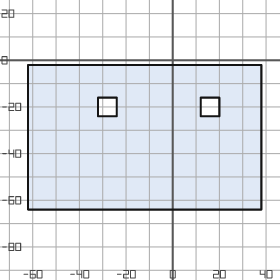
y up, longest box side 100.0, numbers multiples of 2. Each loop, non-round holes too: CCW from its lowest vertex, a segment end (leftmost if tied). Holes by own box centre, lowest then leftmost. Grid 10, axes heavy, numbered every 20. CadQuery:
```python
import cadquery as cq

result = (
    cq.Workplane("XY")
    .moveTo(-62.0, -64.0)
    .lineTo(38.0, -64.0)
    .lineTo(38.0, -2.0)
    .lineTo(-62.0, -2.0)
    .close()
    .moveTo(-32.0, -24.0)
    .lineTo(-24.0, -24.0)
    .lineTo(-24.0, -16.0)
    .lineTo(-32.0, -16.0)
    .close()
    .moveTo(12.0, -24.0)
    .lineTo(20.0, -24.0)
    .lineTo(20.0, -16.0)
    .lineTo(12.0, -16.0)
    .close()
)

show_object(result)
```